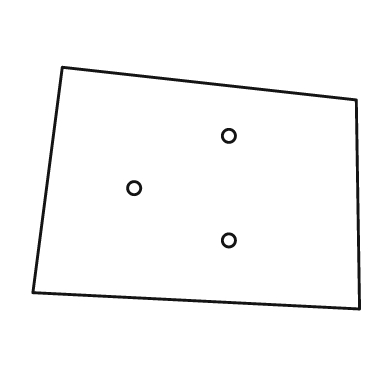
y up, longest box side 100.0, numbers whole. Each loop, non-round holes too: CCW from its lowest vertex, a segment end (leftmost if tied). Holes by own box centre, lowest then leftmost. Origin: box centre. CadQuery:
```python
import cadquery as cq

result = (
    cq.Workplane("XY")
    .moveTo(50.0, -37.0)
    .lineTo(49.0, 27.0)
    .lineTo(-41.0, 37.0)
    .lineTo(-50.0, -32.0)
    .close()
    .moveTo(10.0, -16.0)
    .circle(2.0)
    .moveTo(-19.0, 0.0)
    .circle(2.0)
    .moveTo(10.0, 16.0)
    .circle(2.0)
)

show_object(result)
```